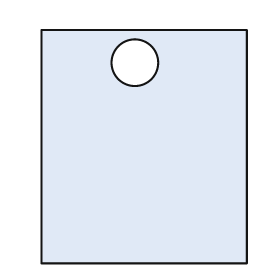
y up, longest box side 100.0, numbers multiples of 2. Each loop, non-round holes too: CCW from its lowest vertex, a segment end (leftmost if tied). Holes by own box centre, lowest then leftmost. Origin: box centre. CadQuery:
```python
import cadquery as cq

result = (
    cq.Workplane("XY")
    .moveTo(-44.0, -50.0)
    .lineTo(44.0, -50.0)
    .lineTo(44.0, 50.0)
    .lineTo(-44.0, 50.0)
    .close()
    .moveTo(-4.0, 36.0)
    .circle(10.0)
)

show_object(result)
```